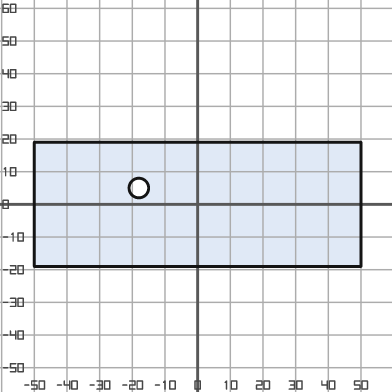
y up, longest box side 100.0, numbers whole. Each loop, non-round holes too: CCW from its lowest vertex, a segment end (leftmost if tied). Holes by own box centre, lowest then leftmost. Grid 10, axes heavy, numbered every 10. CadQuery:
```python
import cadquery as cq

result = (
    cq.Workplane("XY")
    .moveTo(-50.0, -19.0)
    .lineTo(50.0, -19.0)
    .lineTo(50.0, 19.0)
    .lineTo(-50.0, 19.0)
    .close()
    .moveTo(-18.0, 5.0)
    .circle(3.0)
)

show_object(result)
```